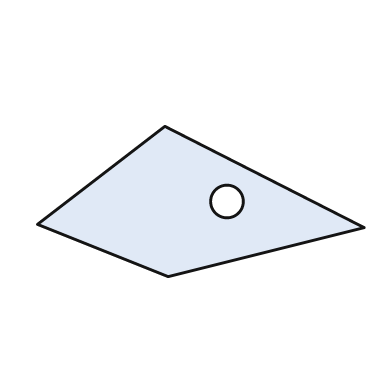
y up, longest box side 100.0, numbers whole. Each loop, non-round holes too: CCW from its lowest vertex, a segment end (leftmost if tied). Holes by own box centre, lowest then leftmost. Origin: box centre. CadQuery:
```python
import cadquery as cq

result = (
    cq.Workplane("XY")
    .moveTo(-10.0, -23.0)
    .lineTo(50.0, -8.0)
    .lineTo(-11.0, 23.0)
    .lineTo(-50.0, -7.0)
    .close()
    .moveTo(8.0, 0.0)
    .circle(5.0)
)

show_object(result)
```